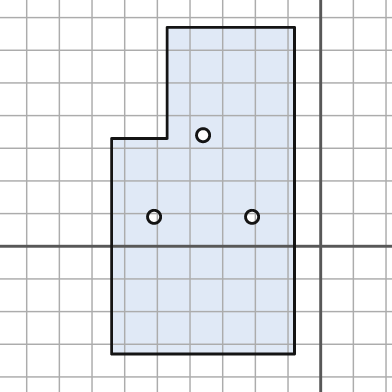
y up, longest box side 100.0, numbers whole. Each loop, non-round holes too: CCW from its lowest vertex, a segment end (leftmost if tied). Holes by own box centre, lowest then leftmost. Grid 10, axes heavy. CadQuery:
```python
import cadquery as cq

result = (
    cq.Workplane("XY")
    .moveTo(-64.0, -33.0)
    .lineTo(-8.0, -33.0)
    .lineTo(-8.0, 67.0)
    .lineTo(-47.0, 67.0)
    .lineTo(-47.0, 33.0)
    .lineTo(-64.0, 33.0)
    .close()
    .moveTo(-51.0, 9.0)
    .circle(2.0)
    .moveTo(-21.0, 9.0)
    .circle(2.0)
    .moveTo(-36.0, 34.0)
    .circle(2.0)
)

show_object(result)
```